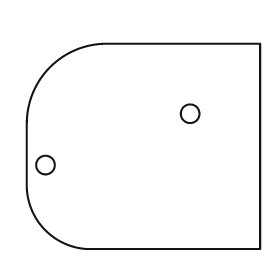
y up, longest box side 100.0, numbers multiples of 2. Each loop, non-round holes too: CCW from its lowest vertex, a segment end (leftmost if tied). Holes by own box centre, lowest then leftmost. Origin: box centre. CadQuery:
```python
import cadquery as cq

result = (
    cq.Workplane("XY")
    .moveTo(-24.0, -44.0)
    .lineTo(50.0, -44.0)
    .lineTo(50.0, 44.0)
    .lineTo(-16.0, 44.0)
    .threePointArc((-40.0, 34.0), (-50.0, 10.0))
    .lineTo(-50.0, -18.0)
    .threePointArc((-42.0, -36.0), (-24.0, -44.0))
    .close()
    .moveTo(-42.0, -8.0)
    .circle(4.0)
    .moveTo(20.0, 14.0)
    .circle(4.0)
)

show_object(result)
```